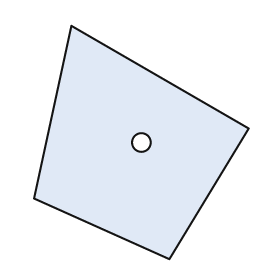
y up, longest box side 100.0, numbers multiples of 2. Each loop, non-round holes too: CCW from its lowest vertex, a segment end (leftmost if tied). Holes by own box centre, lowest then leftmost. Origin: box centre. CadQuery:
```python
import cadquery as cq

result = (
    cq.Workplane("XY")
    .moveTo(12.0, -50.0)
    .lineTo(46.0, 6.0)
    .lineTo(-30.0, 50.0)
    .lineTo(-46.0, -24.0)
    .close()
    .moveTo(0.0, 0.0)
    .circle(4.0)
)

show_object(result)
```